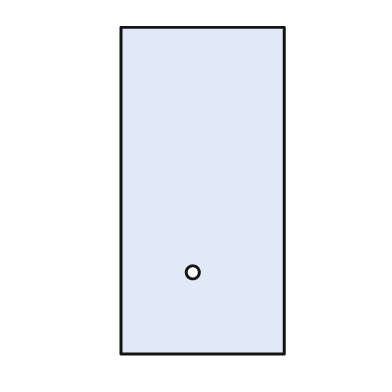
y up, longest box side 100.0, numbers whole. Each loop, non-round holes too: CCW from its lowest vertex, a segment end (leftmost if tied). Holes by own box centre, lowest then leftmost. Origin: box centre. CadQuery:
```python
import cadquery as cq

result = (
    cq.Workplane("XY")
    .moveTo(-25.0, -50.0)
    .lineTo(25.0, -50.0)
    .lineTo(25.0, 50.0)
    .lineTo(-25.0, 50.0)
    .close()
    .moveTo(-3.0, -25.0)
    .circle(2.0)
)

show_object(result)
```